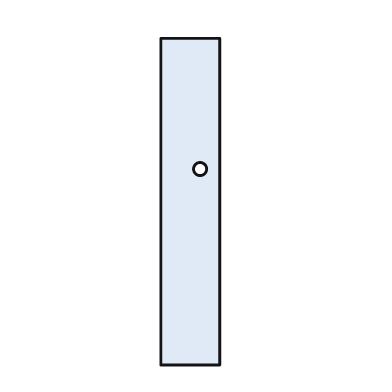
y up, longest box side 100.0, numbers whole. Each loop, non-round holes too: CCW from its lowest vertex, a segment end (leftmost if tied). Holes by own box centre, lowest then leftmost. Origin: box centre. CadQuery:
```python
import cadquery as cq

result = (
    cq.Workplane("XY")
    .moveTo(-9.0, -50.0)
    .lineTo(9.0, -50.0)
    .lineTo(9.0, 50.0)
    .lineTo(-9.0, 50.0)
    .close()
    .moveTo(3.0, 10.0)
    .circle(2.0)
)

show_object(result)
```